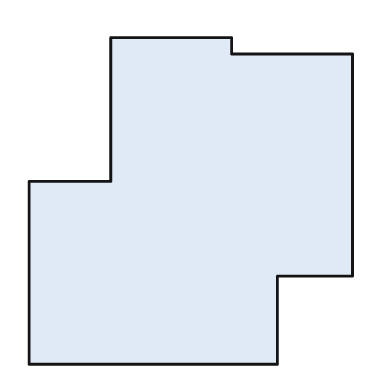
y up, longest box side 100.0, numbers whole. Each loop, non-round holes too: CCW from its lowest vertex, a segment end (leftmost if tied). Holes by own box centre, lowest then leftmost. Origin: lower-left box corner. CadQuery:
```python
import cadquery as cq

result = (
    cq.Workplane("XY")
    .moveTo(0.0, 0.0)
    .lineTo(76.0, 0.0)
    .lineTo(76.0, 27.0)
    .lineTo(99.0, 27.0)
    .lineTo(99.0, 95.0)
    .lineTo(62.0, 95.0)
    .lineTo(62.0, 100.0)
    .lineTo(25.0, 100.0)
    .lineTo(25.0, 56.0)
    .lineTo(0.0, 56.0)
    .close()
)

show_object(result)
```